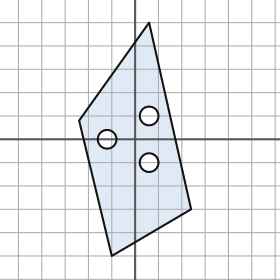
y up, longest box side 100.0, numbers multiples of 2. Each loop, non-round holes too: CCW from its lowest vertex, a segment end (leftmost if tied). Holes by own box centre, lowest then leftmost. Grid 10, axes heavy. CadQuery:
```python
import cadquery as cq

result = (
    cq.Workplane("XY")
    .moveTo(-10.0, -50.0)
    .lineTo(24.0, -30.0)
    .lineTo(6.0, 50.0)
    .lineTo(-24.0, 8.0)
    .close()
    .moveTo(6.0, -10.0)
    .circle(4.0)
    .moveTo(-12.0, 0.0)
    .circle(4.0)
    .moveTo(6.0, 10.0)
    .circle(4.0)
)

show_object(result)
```